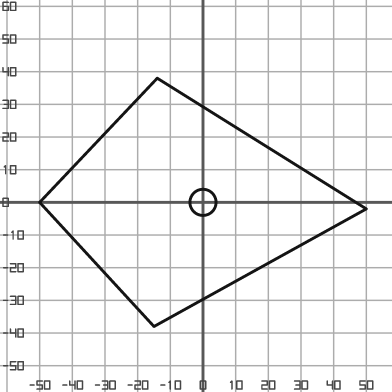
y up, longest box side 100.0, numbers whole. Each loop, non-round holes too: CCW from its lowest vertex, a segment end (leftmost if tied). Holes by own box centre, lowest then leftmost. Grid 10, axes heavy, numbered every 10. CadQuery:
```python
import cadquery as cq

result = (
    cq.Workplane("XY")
    .moveTo(-15.0, -38.0)
    .lineTo(50.0, -2.0)
    .lineTo(-14.0, 38.0)
    .lineTo(-50.0, 0.0)
    .close()
    .moveTo(0.0, 0.0)
    .circle(4.0)
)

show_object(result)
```